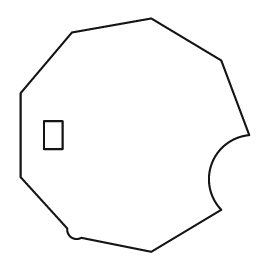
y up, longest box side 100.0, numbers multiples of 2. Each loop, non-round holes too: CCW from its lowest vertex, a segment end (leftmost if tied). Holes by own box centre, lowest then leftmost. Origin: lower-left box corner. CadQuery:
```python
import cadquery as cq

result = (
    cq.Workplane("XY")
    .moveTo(56.0, 0.0)
    .lineTo(86.0, 18.0)
    .threePointArc((82.0, 38.0), (98.0, 50.0))
    .lineTo(86.0, 82.0)
    .lineTo(56.0, 100.0)
    .lineTo(22.0, 94.0)
    .lineTo(0.0, 68.0)
    .lineTo(0.0, 32.0)
    .lineTo(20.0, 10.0)
    .threePointArc((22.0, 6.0), (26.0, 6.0))
    .close()
    .moveTo(10.0, 44.0)
    .lineTo(18.0, 44.0)
    .lineTo(18.0, 56.0)
    .lineTo(10.0, 56.0)
    .close()
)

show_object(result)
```